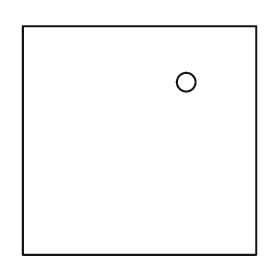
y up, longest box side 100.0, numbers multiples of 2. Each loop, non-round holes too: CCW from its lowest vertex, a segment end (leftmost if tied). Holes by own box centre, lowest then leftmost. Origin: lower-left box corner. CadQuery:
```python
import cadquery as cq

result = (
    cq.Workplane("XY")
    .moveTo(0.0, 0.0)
    .lineTo(100.0, 0.0)
    .lineTo(100.0, 98.0)
    .lineTo(0.0, 98.0)
    .close()
    .moveTo(70.0, 74.0)
    .circle(4.0)
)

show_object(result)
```